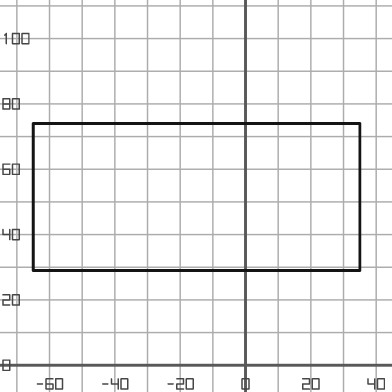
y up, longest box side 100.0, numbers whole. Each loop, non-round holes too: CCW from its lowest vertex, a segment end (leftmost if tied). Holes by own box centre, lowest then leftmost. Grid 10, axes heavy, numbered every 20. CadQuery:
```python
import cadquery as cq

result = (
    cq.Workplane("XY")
    .moveTo(-65.0, 29.0)
    .lineTo(35.0, 29.0)
    .lineTo(35.0, 74.0)
    .lineTo(-65.0, 74.0)
    .close()
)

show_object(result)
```